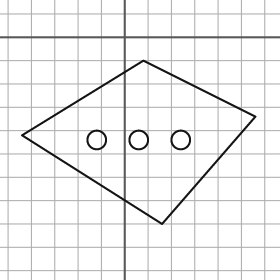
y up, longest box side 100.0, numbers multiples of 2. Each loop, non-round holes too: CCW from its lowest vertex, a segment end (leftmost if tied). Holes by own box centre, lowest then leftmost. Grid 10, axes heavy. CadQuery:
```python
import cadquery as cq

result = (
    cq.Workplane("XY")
    .moveTo(16.0, -80.0)
    .lineTo(56.0, -34.0)
    .lineTo(8.0, -10.0)
    .lineTo(-44.0, -42.0)
    .close()
    .moveTo(-12.0, -44.0)
    .circle(4.0)
    .moveTo(6.0, -44.0)
    .circle(4.0)
    .moveTo(24.0, -44.0)
    .circle(4.0)
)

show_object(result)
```